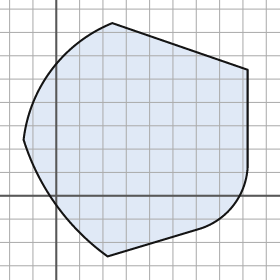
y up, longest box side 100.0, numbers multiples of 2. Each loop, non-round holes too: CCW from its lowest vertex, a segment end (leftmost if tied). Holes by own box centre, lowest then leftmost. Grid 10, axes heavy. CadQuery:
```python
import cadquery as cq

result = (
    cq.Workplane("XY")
    .moveTo(22.0, -26.0)
    .lineTo(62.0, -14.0)
    .threePointArc((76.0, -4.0), (82.0, 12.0))
    .lineTo(82.0, 54.0)
    .lineTo(24.0, 74.0)
    .threePointArc((-2.0, 54.0), (-14.0, 24.0))
    .threePointArc((0.0, -4.0), (22.0, -26.0))
    .close()
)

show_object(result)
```